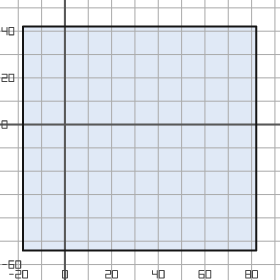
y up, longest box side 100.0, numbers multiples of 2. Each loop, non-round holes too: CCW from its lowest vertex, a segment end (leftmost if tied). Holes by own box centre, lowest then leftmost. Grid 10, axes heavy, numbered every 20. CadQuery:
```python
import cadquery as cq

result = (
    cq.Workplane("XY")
    .moveTo(-18.0, -54.0)
    .lineTo(82.0, -54.0)
    .lineTo(82.0, 42.0)
    .lineTo(-18.0, 42.0)
    .close()
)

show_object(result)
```